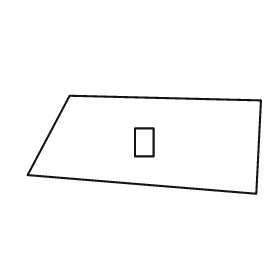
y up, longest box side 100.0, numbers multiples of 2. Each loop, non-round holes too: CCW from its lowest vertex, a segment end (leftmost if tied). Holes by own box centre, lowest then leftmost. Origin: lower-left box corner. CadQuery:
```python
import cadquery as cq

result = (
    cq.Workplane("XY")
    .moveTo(98.0, 0.0)
    .lineTo(100.0, 40.0)
    .lineTo(18.0, 42.0)
    .lineTo(0.0, 8.0)
    .close()
    .moveTo(46.0, 16.0)
    .lineTo(54.0, 16.0)
    .lineTo(54.0, 28.0)
    .lineTo(46.0, 28.0)
    .close()
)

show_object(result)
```